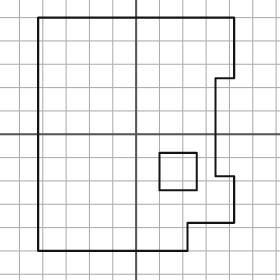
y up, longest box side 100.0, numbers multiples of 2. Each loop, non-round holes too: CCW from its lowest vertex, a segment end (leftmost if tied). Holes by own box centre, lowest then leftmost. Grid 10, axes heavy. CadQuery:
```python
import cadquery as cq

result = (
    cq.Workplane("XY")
    .moveTo(-42.0, -50.0)
    .lineTo(22.0, -50.0)
    .lineTo(22.0, -38.0)
    .lineTo(42.0, -38.0)
    .lineTo(42.0, -18.0)
    .lineTo(34.0, -18.0)
    .lineTo(34.0, 24.0)
    .lineTo(42.0, 24.0)
    .lineTo(42.0, 50.0)
    .lineTo(-42.0, 50.0)
    .close()
    .moveTo(10.0, -24.0)
    .lineTo(26.0, -24.0)
    .lineTo(26.0, -8.0)
    .lineTo(10.0, -8.0)
    .close()
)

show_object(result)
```